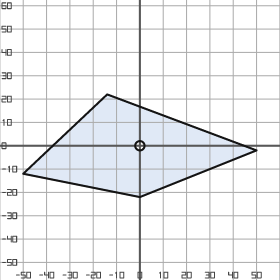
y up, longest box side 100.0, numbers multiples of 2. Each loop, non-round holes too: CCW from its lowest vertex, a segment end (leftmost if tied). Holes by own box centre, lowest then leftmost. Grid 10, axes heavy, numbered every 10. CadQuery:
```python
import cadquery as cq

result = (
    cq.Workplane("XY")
    .moveTo(0.0, -22.0)
    .lineTo(50.0, -2.0)
    .lineTo(-14.0, 22.0)
    .lineTo(-50.0, -12.0)
    .close()
    .moveTo(0.0, 0.0)
    .circle(2.0)
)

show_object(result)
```